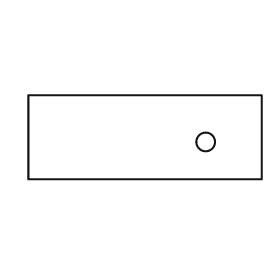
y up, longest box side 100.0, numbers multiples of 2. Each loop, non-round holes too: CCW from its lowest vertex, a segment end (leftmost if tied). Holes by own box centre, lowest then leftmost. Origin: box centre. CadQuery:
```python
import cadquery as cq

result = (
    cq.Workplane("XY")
    .moveTo(-50.0, -18.0)
    .lineTo(50.0, -18.0)
    .lineTo(50.0, 18.0)
    .lineTo(-50.0, 18.0)
    .close()
    .moveTo(26.0, -2.0)
    .circle(4.0)
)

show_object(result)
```